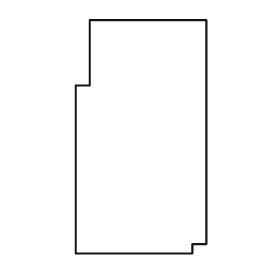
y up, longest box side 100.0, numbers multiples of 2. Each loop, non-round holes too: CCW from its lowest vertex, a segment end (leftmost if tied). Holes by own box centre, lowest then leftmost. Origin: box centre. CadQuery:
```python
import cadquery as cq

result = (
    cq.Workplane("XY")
    .moveTo(-28.0, -50.0)
    .lineTo(22.0, -50.0)
    .lineTo(22.0, -46.0)
    .lineTo(28.0, -46.0)
    .lineTo(28.0, 50.0)
    .lineTo(-22.0, 50.0)
    .lineTo(-22.0, 22.0)
    .lineTo(-28.0, 22.0)
    .close()
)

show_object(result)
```